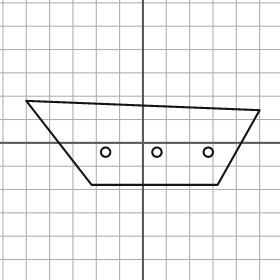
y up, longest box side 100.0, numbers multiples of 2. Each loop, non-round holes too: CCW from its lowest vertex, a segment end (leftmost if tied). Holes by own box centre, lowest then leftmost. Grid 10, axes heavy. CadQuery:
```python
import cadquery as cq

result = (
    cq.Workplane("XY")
    .moveTo(-22.0, -18.0)
    .lineTo(32.0, -18.0)
    .lineTo(50.0, 14.0)
    .lineTo(-50.0, 18.0)
    .close()
    .moveTo(-16.0, -4.0)
    .circle(2.0)
    .moveTo(6.0, -4.0)
    .circle(2.0)
    .moveTo(28.0, -4.0)
    .circle(2.0)
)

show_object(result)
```